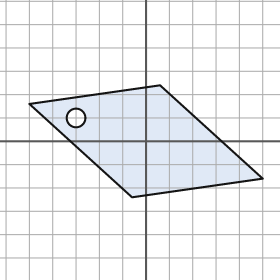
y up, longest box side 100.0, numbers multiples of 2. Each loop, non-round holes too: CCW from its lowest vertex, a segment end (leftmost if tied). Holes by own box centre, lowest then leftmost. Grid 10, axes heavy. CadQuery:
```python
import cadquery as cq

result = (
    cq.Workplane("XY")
    .moveTo(-6.0, -24.0)
    .lineTo(50.0, -16.0)
    .lineTo(6.0, 24.0)
    .lineTo(-50.0, 16.0)
    .close()
    .moveTo(-30.0, 10.0)
    .circle(4.0)
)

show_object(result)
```